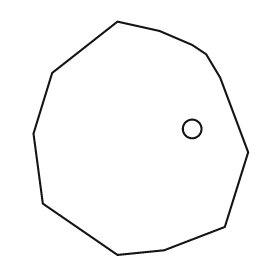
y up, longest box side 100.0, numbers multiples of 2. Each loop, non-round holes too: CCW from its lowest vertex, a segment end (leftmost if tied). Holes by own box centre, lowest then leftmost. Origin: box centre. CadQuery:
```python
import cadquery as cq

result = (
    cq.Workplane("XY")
    .moveTo(-10.0, -50.0)
    .lineTo(10.0, -48.0)
    .lineTo(36.0, -38.0)
    .lineTo(46.0, -6.0)
    .lineTo(34.0, 26.0)
    .lineTo(28.0, 36.0)
    .lineTo(22.0, 40.0)
    .lineTo(8.0, 46.0)
    .lineTo(-10.0, 50.0)
    .lineTo(-38.0, 28.0)
    .lineTo(-46.0, 2.0)
    .lineTo(-42.0, -28.0)
    .close()
    .moveTo(22.0, 4.0)
    .circle(4.0)
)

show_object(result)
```